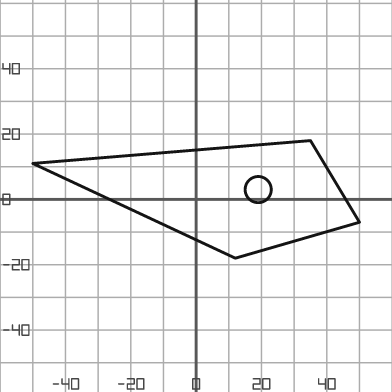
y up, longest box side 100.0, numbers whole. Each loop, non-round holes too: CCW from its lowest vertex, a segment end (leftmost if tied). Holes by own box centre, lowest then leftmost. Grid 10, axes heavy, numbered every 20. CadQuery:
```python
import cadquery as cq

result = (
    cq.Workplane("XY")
    .moveTo(12.0, -18.0)
    .lineTo(50.0, -7.0)
    .lineTo(35.0, 18.0)
    .lineTo(-50.0, 11.0)
    .close()
    .moveTo(19.0, 3.0)
    .circle(4.0)
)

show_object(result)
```